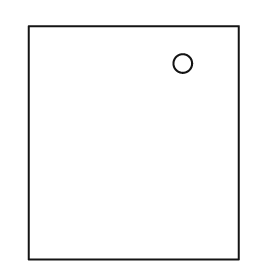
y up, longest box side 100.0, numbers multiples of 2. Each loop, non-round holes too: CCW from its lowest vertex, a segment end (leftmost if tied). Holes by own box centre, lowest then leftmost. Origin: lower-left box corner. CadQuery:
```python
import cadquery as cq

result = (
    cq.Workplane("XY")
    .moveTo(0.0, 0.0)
    .lineTo(90.0, 0.0)
    .lineTo(90.0, 100.0)
    .lineTo(0.0, 100.0)
    .close()
    .moveTo(66.0, 84.0)
    .circle(4.0)
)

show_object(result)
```